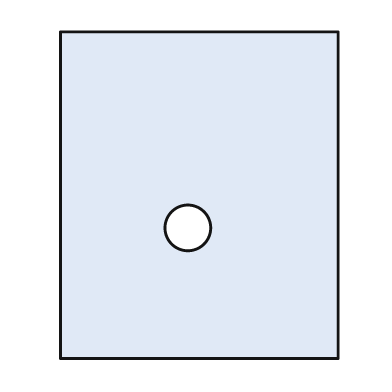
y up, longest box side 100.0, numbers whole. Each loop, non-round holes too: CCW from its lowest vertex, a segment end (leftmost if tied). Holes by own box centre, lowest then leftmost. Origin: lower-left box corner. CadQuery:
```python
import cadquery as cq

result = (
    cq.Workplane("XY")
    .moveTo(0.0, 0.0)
    .lineTo(85.0, 0.0)
    .lineTo(85.0, 100.0)
    .lineTo(0.0, 100.0)
    .close()
    .moveTo(39.0, 40.0)
    .circle(7.0)
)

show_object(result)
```